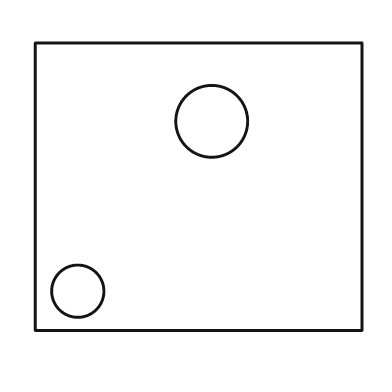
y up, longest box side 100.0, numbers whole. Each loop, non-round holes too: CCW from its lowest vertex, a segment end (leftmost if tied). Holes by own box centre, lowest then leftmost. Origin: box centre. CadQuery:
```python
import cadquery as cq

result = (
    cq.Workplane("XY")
    .moveTo(-50.0, -44.0)
    .lineTo(50.0, -44.0)
    .lineTo(50.0, 44.0)
    .lineTo(-50.0, 44.0)
    .close()
    .moveTo(-37.0, -32.0)
    .circle(8.0)
    .moveTo(4.0, 20.0)
    .circle(11.0)
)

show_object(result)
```